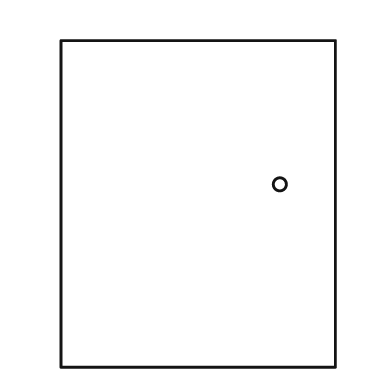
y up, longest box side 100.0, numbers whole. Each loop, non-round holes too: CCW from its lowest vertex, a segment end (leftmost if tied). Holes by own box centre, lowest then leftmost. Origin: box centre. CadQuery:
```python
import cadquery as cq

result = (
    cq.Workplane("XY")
    .moveTo(-42.0, -50.0)
    .lineTo(42.0, -50.0)
    .lineTo(42.0, 50.0)
    .lineTo(-42.0, 50.0)
    .close()
    .moveTo(25.0, 6.0)
    .circle(2.0)
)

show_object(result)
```